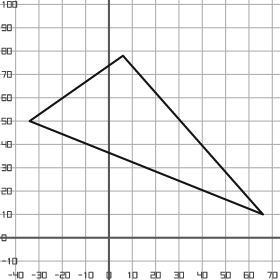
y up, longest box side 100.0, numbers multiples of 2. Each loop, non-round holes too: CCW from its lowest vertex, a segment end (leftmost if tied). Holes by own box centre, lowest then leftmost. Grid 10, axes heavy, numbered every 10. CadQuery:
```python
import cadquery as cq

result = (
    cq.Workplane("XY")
    .moveTo(66.0, 10.0)
    .lineTo(6.0, 78.0)
    .lineTo(-34.0, 50.0)
    .close()
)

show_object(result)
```